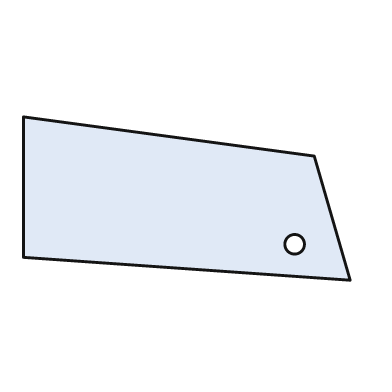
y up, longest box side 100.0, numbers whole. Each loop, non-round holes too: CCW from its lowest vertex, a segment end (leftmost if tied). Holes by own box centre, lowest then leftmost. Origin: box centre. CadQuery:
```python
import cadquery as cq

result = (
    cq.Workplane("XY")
    .moveTo(50.0, -25.0)
    .lineTo(39.0, 13.0)
    .lineTo(-50.0, 25.0)
    .lineTo(-50.0, -18.0)
    .close()
    .moveTo(33.0, -14.0)
    .circle(3.0)
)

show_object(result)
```